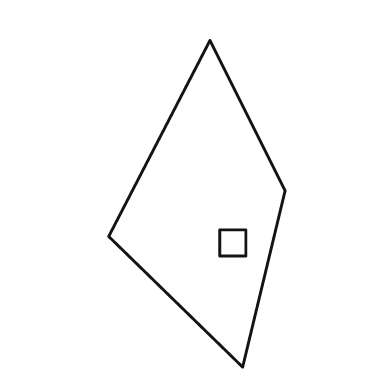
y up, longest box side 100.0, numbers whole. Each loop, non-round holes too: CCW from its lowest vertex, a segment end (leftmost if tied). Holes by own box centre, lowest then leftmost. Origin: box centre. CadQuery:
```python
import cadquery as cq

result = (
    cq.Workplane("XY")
    .moveTo(14.0, -50.0)
    .lineTo(27.0, 4.0)
    .lineTo(4.0, 50.0)
    .lineTo(-27.0, -10.0)
    .close()
    .moveTo(7.0, -16.0)
    .lineTo(15.0, -16.0)
    .lineTo(15.0, -8.0)
    .lineTo(7.0, -8.0)
    .close()
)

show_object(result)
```